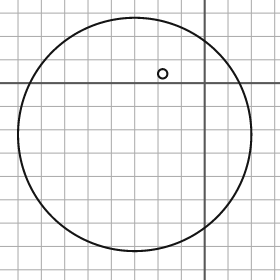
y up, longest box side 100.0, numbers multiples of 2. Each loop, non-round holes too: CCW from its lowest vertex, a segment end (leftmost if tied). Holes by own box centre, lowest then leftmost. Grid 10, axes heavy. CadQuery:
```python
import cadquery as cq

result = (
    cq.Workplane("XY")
    .moveTo(-30.0, -22.0)
    .circle(50.0)
    .moveTo(-18.0, 4.0)
    .circle(2.0)
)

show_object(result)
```